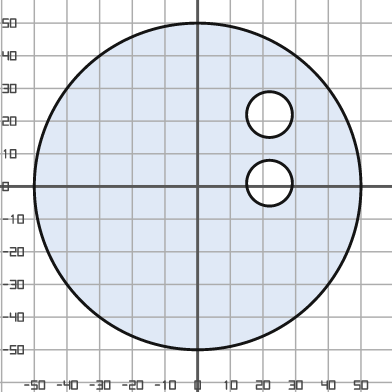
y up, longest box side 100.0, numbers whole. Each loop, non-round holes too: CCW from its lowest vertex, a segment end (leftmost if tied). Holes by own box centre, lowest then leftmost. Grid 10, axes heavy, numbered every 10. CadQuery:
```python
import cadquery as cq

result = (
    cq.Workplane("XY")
    .moveTo(0.0, 0.0)
    .circle(50.0)
    .moveTo(22.0, 1.0)
    .circle(7.0)
    .moveTo(22.0, 22.0)
    .circle(7.0)
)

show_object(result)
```